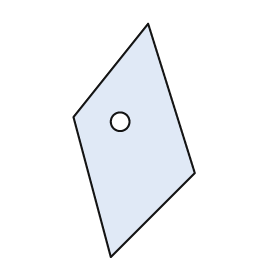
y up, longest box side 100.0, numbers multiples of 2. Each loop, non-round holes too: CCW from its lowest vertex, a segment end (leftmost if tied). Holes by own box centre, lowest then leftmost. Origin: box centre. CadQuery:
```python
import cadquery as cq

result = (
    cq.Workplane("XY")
    .moveTo(-10.0, -50.0)
    .lineTo(26.0, -14.0)
    .lineTo(6.0, 50.0)
    .lineTo(-26.0, 10.0)
    .close()
    .moveTo(-6.0, 8.0)
    .circle(4.0)
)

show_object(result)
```